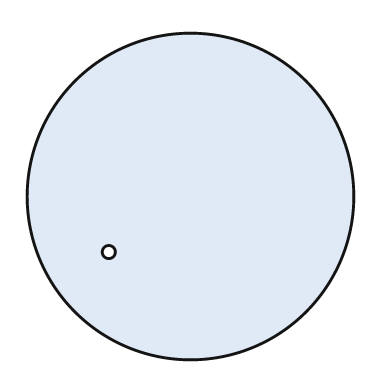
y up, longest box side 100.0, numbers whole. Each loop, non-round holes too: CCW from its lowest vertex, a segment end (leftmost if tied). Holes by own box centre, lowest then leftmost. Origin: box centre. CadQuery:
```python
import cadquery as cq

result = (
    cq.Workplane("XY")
    .moveTo(0.0, 0.0)
    .circle(50.0)
    .moveTo(-25.0, -17.0)
    .circle(2.0)
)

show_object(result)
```